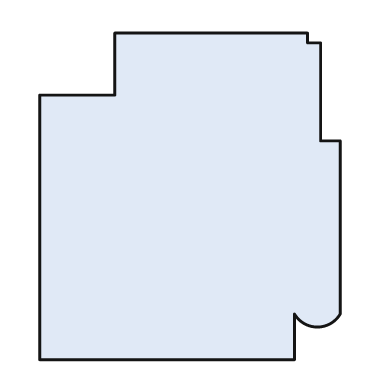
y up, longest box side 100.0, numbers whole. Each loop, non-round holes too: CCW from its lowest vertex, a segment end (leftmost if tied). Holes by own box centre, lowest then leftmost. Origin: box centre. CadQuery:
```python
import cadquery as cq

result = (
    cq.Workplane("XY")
    .moveTo(-46.0, -50.0)
    .lineTo(32.0, -50.0)
    .lineTo(32.0, -36.0)
    .threePointArc((39.0, -40.0), (46.0, -36.0))
    .lineTo(46.0, 17.0)
    .lineTo(40.0, 17.0)
    .lineTo(40.0, 47.0)
    .lineTo(36.0, 47.0)
    .lineTo(36.0, 50.0)
    .lineTo(-23.0, 50.0)
    .lineTo(-23.0, 31.0)
    .lineTo(-46.0, 31.0)
    .close()
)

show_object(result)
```